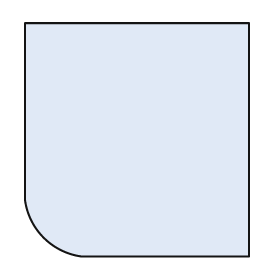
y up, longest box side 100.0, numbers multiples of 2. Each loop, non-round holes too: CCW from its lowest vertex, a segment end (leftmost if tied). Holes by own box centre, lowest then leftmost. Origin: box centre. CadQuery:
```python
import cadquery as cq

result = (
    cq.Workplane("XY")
    .moveTo(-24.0, -50.0)
    .lineTo(48.0, -50.0)
    .lineTo(48.0, 50.0)
    .lineTo(-48.0, 50.0)
    .lineTo(-48.0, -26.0)
    .threePointArc((-40.0, -42.0), (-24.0, -50.0))
    .close()
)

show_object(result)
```